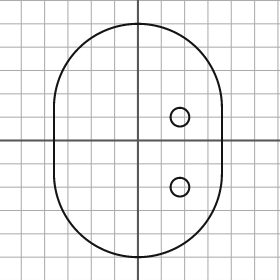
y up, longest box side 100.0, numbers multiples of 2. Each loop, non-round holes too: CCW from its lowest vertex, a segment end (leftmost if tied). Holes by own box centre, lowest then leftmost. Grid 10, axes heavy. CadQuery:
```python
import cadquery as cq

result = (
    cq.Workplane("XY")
    .moveTo(-36.0, -14.0)
    .threePointArc((0.0, -50.0), (36.0, -14.0))
    .lineTo(36.0, 14.0)
    .threePointArc((0.0, 50.0), (-36.0, 14.0))
    .close()
    .moveTo(18.0, -20.0)
    .circle(4.0)
    .moveTo(18.0, 10.0)
    .circle(4.0)
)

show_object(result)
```